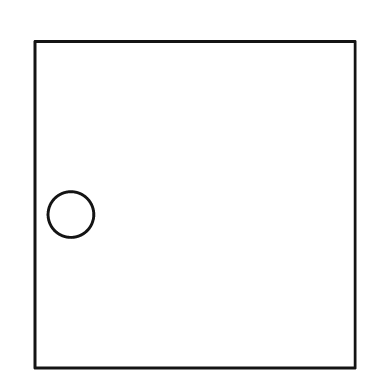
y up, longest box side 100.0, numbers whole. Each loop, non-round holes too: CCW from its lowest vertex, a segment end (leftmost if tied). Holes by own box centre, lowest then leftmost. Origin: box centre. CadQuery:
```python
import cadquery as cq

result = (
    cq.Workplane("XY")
    .moveTo(-49.0, -50.0)
    .lineTo(49.0, -50.0)
    .lineTo(49.0, 50.0)
    .lineTo(-49.0, 50.0)
    .close()
    .moveTo(-38.0, -3.0)
    .circle(7.0)
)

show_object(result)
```